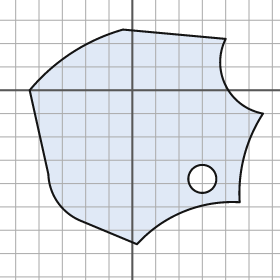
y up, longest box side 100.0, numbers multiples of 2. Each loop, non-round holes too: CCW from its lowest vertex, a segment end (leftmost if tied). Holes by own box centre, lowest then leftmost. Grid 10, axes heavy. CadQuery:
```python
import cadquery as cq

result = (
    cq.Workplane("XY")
    .moveTo(2.0, -66.0)
    .threePointArc((22.0, -52.0), (46.0, -48.0))
    .threePointArc((48.0, -28.0), (56.0, -10.0))
    .threePointArc((40.0, 2.0), (40.0, 22.0))
    .lineTo(-4.0, 26.0)
    .threePointArc((-26.0, 16.0), (-44.0, 0.0))
    .lineTo(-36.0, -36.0)
    .threePointArc((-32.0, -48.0), (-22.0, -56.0))
    .close()
    .moveTo(30.0, -38.0)
    .circle(6.0)
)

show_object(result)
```